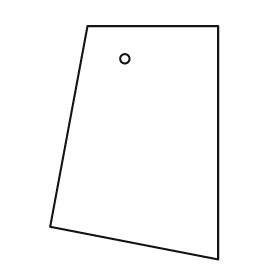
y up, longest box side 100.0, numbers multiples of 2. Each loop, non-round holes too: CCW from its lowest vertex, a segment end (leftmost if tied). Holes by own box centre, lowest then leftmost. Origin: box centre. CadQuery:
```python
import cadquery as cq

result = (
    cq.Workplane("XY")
    .moveTo(36.0, -50.0)
    .lineTo(36.0, 50.0)
    .lineTo(-20.0, 50.0)
    .lineTo(-36.0, -36.0)
    .close()
    .moveTo(-4.0, 36.0)
    .circle(2.0)
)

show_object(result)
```